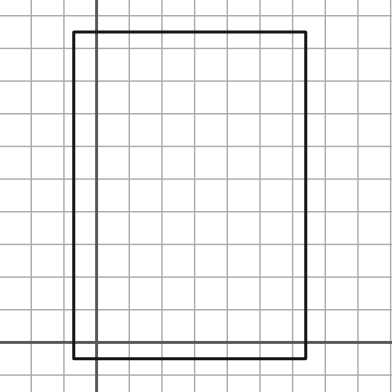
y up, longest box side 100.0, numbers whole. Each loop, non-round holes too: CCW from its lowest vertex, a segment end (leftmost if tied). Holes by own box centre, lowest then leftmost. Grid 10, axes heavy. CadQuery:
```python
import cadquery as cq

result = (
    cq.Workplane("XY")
    .moveTo(-7.0, -5.0)
    .lineTo(64.0, -5.0)
    .lineTo(64.0, 95.0)
    .lineTo(-7.0, 95.0)
    .close()
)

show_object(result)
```